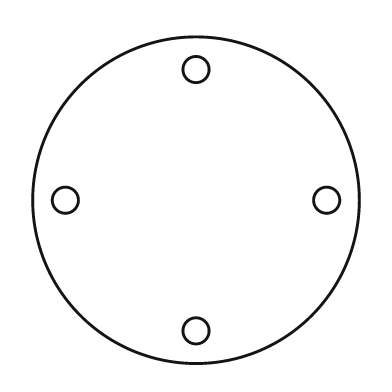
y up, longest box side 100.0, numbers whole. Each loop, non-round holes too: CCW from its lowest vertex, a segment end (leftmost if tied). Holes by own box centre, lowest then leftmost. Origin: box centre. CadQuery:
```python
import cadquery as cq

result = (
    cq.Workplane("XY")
    .moveTo(0.0, 0.0)
    .circle(50.0)
    .moveTo(0.0, -40.0)
    .circle(4.0)
    .moveTo(-40.0, 0.0)
    .circle(4.0)
    .moveTo(40.0, 0.0)
    .circle(4.0)
    .moveTo(0.0, 40.0)
    .circle(4.0)
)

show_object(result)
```